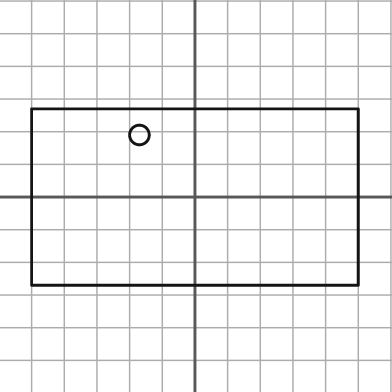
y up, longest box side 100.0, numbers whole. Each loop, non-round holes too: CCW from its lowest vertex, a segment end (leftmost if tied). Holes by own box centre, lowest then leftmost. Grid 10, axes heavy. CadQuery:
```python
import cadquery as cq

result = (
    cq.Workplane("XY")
    .moveTo(-50.0, -27.0)
    .lineTo(50.0, -27.0)
    .lineTo(50.0, 27.0)
    .lineTo(-50.0, 27.0)
    .close()
    .moveTo(-17.0, 19.0)
    .circle(3.0)
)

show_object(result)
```